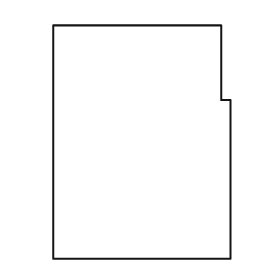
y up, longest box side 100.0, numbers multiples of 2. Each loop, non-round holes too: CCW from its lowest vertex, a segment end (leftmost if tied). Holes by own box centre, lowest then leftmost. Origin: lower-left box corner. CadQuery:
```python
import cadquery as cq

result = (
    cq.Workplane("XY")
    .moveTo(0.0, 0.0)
    .lineTo(76.0, 0.0)
    .lineTo(76.0, 68.0)
    .lineTo(72.0, 68.0)
    .lineTo(72.0, 100.0)
    .lineTo(0.0, 100.0)
    .close()
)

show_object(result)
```